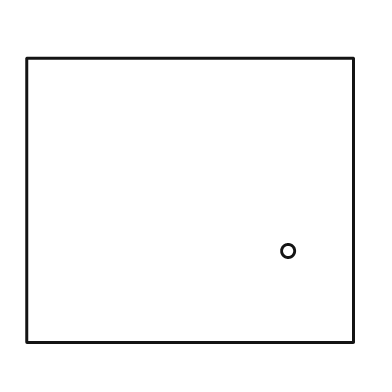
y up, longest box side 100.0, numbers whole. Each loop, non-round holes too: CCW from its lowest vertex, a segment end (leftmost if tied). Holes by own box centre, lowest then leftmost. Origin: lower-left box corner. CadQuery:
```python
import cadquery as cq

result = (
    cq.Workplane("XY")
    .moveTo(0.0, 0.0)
    .lineTo(100.0, 0.0)
    .lineTo(100.0, 87.0)
    .lineTo(0.0, 87.0)
    .close()
    .moveTo(80.0, 28.0)
    .circle(2.0)
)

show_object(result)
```